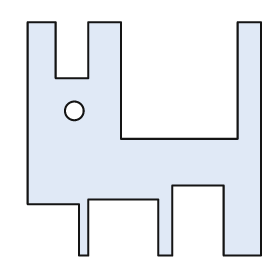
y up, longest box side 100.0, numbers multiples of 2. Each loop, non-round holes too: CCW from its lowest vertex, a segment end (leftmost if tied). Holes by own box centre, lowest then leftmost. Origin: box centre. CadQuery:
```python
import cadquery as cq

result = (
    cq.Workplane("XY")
    .moveTo(-28.0, -50.0)
    .lineTo(-24.0, -50.0)
    .lineTo(-24.0, -26.0)
    .lineTo(6.0, -26.0)
    .lineTo(6.0, -50.0)
    .lineTo(12.0, -50.0)
    .lineTo(12.0, -20.0)
    .lineTo(34.0, -20.0)
    .lineTo(34.0, -50.0)
    .lineTo(50.0, -50.0)
    .lineTo(50.0, 50.0)
    .lineTo(40.0, 50.0)
    .lineTo(40.0, 0.0)
    .lineTo(-10.0, 0.0)
    .lineTo(-10.0, 50.0)
    .lineTo(-24.0, 50.0)
    .lineTo(-24.0, 26.0)
    .lineTo(-38.0, 26.0)
    .lineTo(-38.0, 50.0)
    .lineTo(-50.0, 50.0)
    .lineTo(-50.0, -28.0)
    .lineTo(-28.0, -28.0)
    .close()
    .moveTo(-30.0, 12.0)
    .circle(4.0)
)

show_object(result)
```